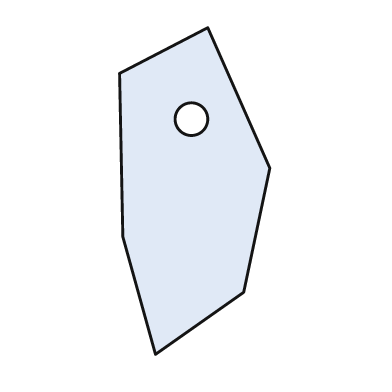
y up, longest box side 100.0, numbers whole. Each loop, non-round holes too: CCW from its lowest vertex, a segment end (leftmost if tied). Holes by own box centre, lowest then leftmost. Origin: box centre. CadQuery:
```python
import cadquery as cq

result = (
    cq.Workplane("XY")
    .moveTo(-12.0, -50.0)
    .lineTo(15.0, -31.0)
    .lineTo(23.0, 7.0)
    .lineTo(4.0, 50.0)
    .lineTo(-23.0, 36.0)
    .lineTo(-22.0, -14.0)
    .close()
    .moveTo(-1.0, 22.0)
    .circle(5.0)
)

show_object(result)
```